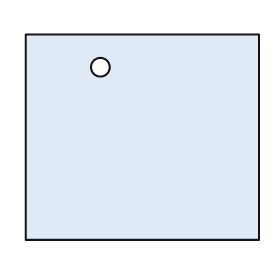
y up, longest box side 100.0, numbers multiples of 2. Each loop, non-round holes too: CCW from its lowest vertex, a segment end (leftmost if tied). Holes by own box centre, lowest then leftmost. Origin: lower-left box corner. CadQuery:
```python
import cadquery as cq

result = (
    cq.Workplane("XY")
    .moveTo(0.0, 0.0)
    .lineTo(100.0, 0.0)
    .lineTo(100.0, 88.0)
    .lineTo(0.0, 88.0)
    .close()
    .moveTo(32.0, 74.0)
    .circle(4.0)
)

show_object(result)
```